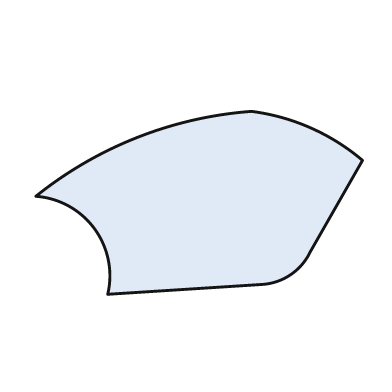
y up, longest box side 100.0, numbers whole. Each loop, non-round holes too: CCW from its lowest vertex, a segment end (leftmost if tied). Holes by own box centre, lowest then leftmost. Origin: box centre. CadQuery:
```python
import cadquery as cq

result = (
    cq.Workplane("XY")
    .moveTo(-28.0, -28.0)
    .lineTo(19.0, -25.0)
    .threePointArc((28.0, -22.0), (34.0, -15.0))
    .lineTo(50.0, 13.0)
    .threePointArc((34.0, 23.0), (16.0, 28.0))
    .threePointArc((-19.0, 20.0), (-50.0, 2.0))
    .threePointArc((-32.0, -8.0), (-28.0, -28.0))
    .close()
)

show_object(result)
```